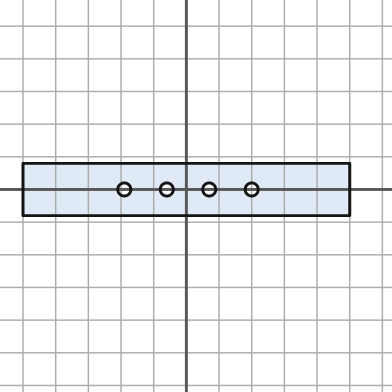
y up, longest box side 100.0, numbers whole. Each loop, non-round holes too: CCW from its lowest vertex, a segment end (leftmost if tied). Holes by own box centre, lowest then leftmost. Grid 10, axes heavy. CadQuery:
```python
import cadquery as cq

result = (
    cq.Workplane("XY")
    .moveTo(-50.0, -8.0)
    .lineTo(50.0, -8.0)
    .lineTo(50.0, 8.0)
    .lineTo(-50.0, 8.0)
    .close()
    .moveTo(-19.0, 0.0)
    .circle(2.0)
    .moveTo(-6.0, 0.0)
    .circle(2.0)
    .moveTo(7.0, 0.0)
    .circle(2.0)
    .moveTo(20.0, 0.0)
    .circle(2.0)
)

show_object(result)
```